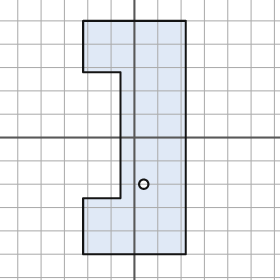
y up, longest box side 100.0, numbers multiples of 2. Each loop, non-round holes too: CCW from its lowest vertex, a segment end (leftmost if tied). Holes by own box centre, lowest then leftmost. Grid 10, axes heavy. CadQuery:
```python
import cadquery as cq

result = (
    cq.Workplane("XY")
    .moveTo(-22.0, -50.0)
    .lineTo(22.0, -50.0)
    .lineTo(22.0, 50.0)
    .lineTo(-22.0, 50.0)
    .lineTo(-22.0, 28.0)
    .lineTo(-6.0, 28.0)
    .lineTo(-6.0, -26.0)
    .lineTo(-22.0, -26.0)
    .close()
    .moveTo(4.0, -20.0)
    .circle(2.0)
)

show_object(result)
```